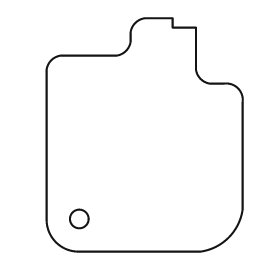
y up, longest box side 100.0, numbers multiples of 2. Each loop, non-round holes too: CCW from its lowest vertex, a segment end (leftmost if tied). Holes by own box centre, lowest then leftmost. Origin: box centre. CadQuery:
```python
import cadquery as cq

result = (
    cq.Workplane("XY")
    .moveTo(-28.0, -50.0)
    .lineTo(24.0, -50.0)
    .threePointArc((36.0, -44.0), (42.0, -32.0))
    .lineTo(42.0, 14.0)
    .threePointArc((40.0, 20.0), (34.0, 22.0))
    .lineTo(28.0, 22.0)
    .threePointArc((24.0, 24.0), (22.0, 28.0))
    .lineTo(22.0, 46.0)
    .lineTo(12.0, 46.0)
    .lineTo(12.0, 50.0)
    .lineTo(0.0, 50.0)
    .threePointArc((-4.0, 48.0), (-6.0, 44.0))
    .lineTo(-6.0, 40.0)
    .threePointArc((-8.0, 36.0), (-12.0, 34.0))
    .lineTo(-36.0, 34.0)
    .threePointArc((-40.0, 32.0), (-42.0, 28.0))
    .lineTo(-42.0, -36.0)
    .threePointArc((-38.0, -46.0), (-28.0, -50.0))
    .close()
    .moveTo(-28.0, -36.0)
    .circle(4.0)
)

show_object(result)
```